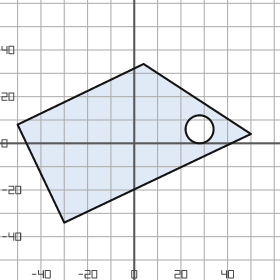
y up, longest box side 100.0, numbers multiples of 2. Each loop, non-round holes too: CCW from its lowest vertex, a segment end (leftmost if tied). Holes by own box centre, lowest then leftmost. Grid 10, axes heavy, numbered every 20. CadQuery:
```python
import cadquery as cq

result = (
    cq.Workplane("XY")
    .moveTo(-30.0, -34.0)
    .lineTo(50.0, 4.0)
    .lineTo(4.0, 34.0)
    .lineTo(-50.0, 8.0)
    .close()
    .moveTo(28.0, 6.0)
    .circle(6.0)
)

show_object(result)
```